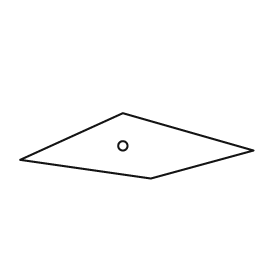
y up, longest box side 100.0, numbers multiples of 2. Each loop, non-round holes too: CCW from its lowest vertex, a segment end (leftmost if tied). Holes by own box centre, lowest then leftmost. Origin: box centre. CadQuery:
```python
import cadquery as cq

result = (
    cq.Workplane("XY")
    .moveTo(6.0, -14.0)
    .lineTo(50.0, -2.0)
    .lineTo(-6.0, 14.0)
    .lineTo(-50.0, -6.0)
    .close()
    .moveTo(-6.0, 0.0)
    .circle(2.0)
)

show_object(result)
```